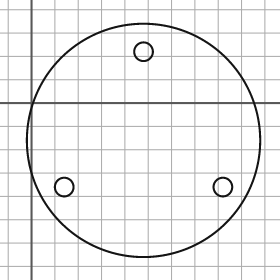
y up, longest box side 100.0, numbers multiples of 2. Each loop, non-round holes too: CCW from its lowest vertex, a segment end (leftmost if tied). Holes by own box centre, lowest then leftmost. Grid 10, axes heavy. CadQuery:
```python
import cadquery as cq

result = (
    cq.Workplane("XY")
    .moveTo(48.0, -16.0)
    .circle(50.0)
    .moveTo(14.0, -36.0)
    .circle(4.0)
    .moveTo(82.0, -36.0)
    .circle(4.0)
    .moveTo(48.0, 22.0)
    .circle(4.0)
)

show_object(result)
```